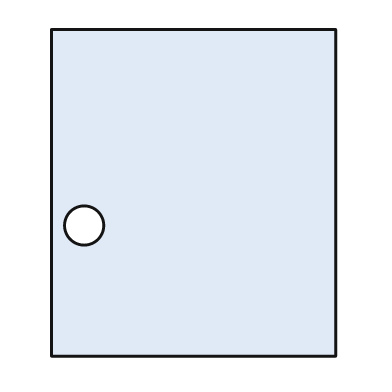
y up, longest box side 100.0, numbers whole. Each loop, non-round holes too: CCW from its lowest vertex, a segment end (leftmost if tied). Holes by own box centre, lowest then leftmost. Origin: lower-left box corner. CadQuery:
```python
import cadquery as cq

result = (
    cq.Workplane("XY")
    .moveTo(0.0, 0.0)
    .lineTo(87.0, 0.0)
    .lineTo(87.0, 100.0)
    .lineTo(0.0, 100.0)
    .close()
    .moveTo(10.0, 40.0)
    .circle(6.0)
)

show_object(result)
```